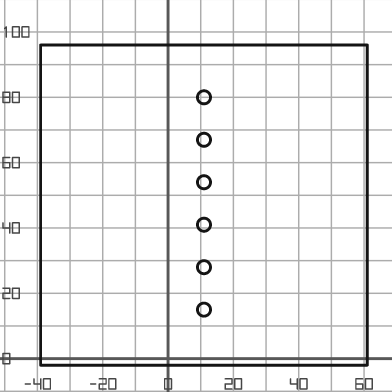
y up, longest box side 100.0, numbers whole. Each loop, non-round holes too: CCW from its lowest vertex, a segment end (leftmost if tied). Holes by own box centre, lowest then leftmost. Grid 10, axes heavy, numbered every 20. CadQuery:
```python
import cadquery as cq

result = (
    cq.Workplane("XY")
    .moveTo(-39.0, -2.0)
    .lineTo(61.0, -2.0)
    .lineTo(61.0, 96.0)
    .lineTo(-39.0, 96.0)
    .close()
    .moveTo(11.0, 15.0)
    .circle(2.0)
    .moveTo(11.0, 28.0)
    .circle(2.0)
    .moveTo(11.0, 41.0)
    .circle(2.0)
    .moveTo(11.0, 54.0)
    .circle(2.0)
    .moveTo(11.0, 67.0)
    .circle(2.0)
    .moveTo(11.0, 80.0)
    .circle(2.0)
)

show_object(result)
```